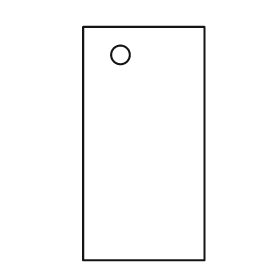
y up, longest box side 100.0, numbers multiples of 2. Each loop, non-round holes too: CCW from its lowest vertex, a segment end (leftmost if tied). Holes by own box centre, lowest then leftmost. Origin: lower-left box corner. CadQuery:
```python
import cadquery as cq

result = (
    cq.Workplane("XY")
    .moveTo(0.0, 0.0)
    .lineTo(52.0, 0.0)
    .lineTo(52.0, 100.0)
    .lineTo(0.0, 100.0)
    .close()
    .moveTo(16.0, 88.0)
    .circle(4.0)
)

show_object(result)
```